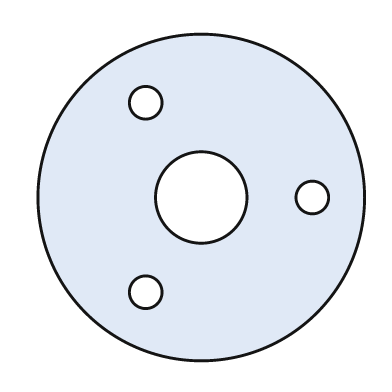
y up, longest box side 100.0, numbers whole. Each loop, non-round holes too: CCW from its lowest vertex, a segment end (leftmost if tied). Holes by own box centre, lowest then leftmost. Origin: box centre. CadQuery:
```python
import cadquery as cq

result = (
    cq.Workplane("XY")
    .moveTo(0.0, 0.0)
    .circle(50.0)
    .moveTo(-17.0, -29.0)
    .circle(5.0)
    .moveTo(0.0, 0.0)
    .circle(14.0)
    .moveTo(34.0, 0.0)
    .circle(5.0)
    .moveTo(-17.0, 29.0)
    .circle(5.0)
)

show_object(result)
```